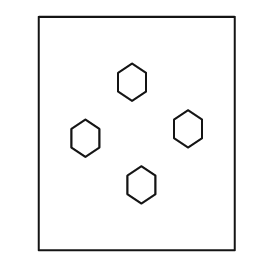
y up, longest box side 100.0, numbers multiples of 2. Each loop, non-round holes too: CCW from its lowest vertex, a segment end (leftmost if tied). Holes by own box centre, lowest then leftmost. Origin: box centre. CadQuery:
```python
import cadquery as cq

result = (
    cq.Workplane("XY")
    .moveTo(-42.0, -50.0)
    .lineTo(42.0, -50.0)
    .lineTo(42.0, 50.0)
    .lineTo(-42.0, 50.0)
    .close()
    .moveTo(2.0, -30.0)
    .lineTo(8.0, -26.0)
    .lineTo(8.0, -18.0)
    .lineTo(2.0, -14.0)
    .lineTo(-4.0, -18.0)
    .lineTo(-4.0, -26.0)
    .close()
    .moveTo(-22.0, -10.0)
    .lineTo(-16.0, -6.0)
    .lineTo(-16.0, 2.0)
    .lineTo(-22.0, 6.0)
    .lineTo(-28.0, 2.0)
    .lineTo(-28.0, -6.0)
    .close()
    .moveTo(22.0, -6.0)
    .lineTo(28.0, -2.0)
    .lineTo(28.0, 6.0)
    .lineTo(22.0, 10.0)
    .lineTo(16.0, 6.0)
    .lineTo(16.0, -2.0)
    .close()
    .moveTo(-2.0, 14.0)
    .lineTo(4.0, 18.0)
    .lineTo(4.0, 26.0)
    .lineTo(-2.0, 30.0)
    .lineTo(-8.0, 26.0)
    .lineTo(-8.0, 18.0)
    .close()
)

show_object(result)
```